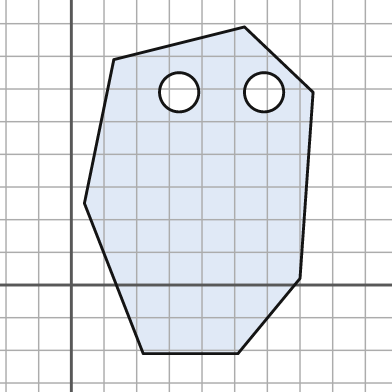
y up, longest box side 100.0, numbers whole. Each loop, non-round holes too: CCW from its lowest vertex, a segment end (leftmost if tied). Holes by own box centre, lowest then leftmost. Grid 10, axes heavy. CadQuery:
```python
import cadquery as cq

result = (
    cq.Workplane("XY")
    .moveTo(22.0, -21.0)
    .lineTo(51.0, -21.0)
    .lineTo(70.0, 2.0)
    .lineTo(74.0, 59.0)
    .lineTo(53.0, 79.0)
    .lineTo(13.0, 69.0)
    .lineTo(4.0, 25.0)
    .close()
    .moveTo(33.0, 59.0)
    .circle(6.0)
    .moveTo(59.0, 59.0)
    .circle(6.0)
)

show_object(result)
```